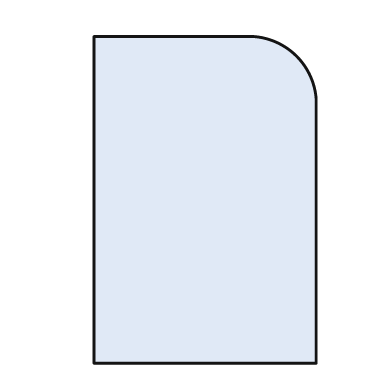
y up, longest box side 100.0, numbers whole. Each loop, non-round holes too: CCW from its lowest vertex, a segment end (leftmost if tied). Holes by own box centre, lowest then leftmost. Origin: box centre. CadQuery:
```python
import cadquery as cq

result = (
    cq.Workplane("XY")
    .moveTo(-34.0, -50.0)
    .lineTo(34.0, -50.0)
    .lineTo(34.0, 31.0)
    .threePointArc((28.0, 44.0), (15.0, 50.0))
    .lineTo(-34.0, 50.0)
    .close()
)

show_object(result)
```